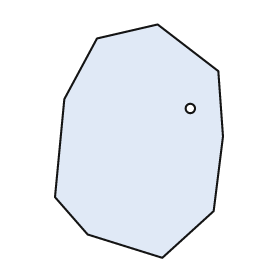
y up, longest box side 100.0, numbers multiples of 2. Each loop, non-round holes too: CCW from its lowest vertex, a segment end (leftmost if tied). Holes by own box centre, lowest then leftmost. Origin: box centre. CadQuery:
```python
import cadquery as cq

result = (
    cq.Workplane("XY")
    .moveTo(10.0, -50.0)
    .lineTo(32.0, -30.0)
    .lineTo(36.0, 2.0)
    .lineTo(34.0, 30.0)
    .lineTo(8.0, 50.0)
    .lineTo(-18.0, 44.0)
    .lineTo(-32.0, 18.0)
    .lineTo(-36.0, -24.0)
    .lineTo(-22.0, -40.0)
    .close()
    .moveTo(22.0, 14.0)
    .circle(2.0)
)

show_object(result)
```